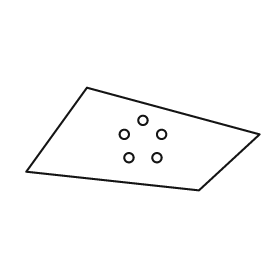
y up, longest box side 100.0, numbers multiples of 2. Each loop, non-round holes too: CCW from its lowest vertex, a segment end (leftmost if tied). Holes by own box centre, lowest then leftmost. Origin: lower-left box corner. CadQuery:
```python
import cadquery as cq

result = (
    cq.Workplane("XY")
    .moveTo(74.0, 0.0)
    .lineTo(100.0, 24.0)
    .lineTo(26.0, 44.0)
    .lineTo(0.0, 8.0)
    .close()
    .moveTo(44.0, 14.0)
    .circle(2.0)
    .moveTo(56.0, 14.0)
    .circle(2.0)
    .moveTo(42.0, 24.0)
    .circle(2.0)
    .moveTo(58.0, 24.0)
    .circle(2.0)
    .moveTo(50.0, 30.0)
    .circle(2.0)
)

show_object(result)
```